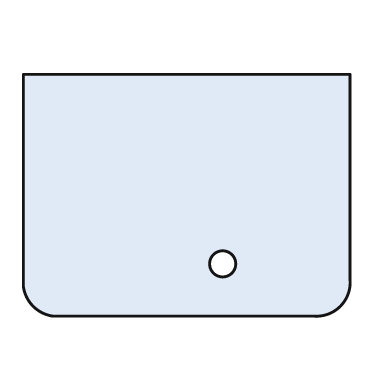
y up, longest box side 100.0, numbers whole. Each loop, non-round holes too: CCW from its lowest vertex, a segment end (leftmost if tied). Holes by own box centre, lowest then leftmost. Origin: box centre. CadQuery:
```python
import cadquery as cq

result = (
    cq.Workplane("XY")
    .moveTo(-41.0, -37.0)
    .lineTo(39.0, -37.0)
    .threePointArc((47.0, -34.0), (50.0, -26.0))
    .lineTo(50.0, 37.0)
    .lineTo(-50.0, 37.0)
    .lineTo(-50.0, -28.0)
    .threePointArc((-47.0, -34.0), (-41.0, -37.0))
    .close()
    .moveTo(11.0, -21.0)
    .circle(4.0)
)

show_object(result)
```